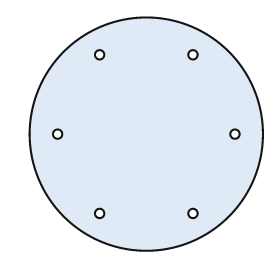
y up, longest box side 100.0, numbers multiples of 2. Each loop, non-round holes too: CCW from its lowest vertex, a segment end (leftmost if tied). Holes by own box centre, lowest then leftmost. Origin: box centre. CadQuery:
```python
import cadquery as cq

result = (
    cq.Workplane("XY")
    .moveTo(0.0, 0.0)
    .circle(50.0)
    .moveTo(-20.0, -34.0)
    .circle(2.0)
    .moveTo(20.0, -34.0)
    .circle(2.0)
    .moveTo(-38.0, 0.0)
    .circle(2.0)
    .moveTo(38.0, 0.0)
    .circle(2.0)
    .moveTo(-20.0, 34.0)
    .circle(2.0)
    .moveTo(20.0, 34.0)
    .circle(2.0)
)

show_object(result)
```